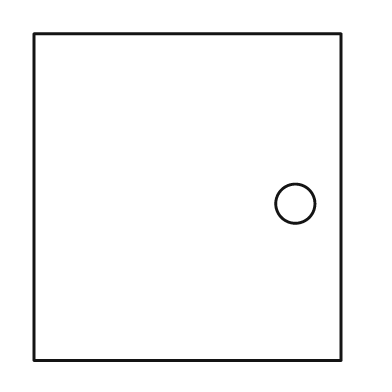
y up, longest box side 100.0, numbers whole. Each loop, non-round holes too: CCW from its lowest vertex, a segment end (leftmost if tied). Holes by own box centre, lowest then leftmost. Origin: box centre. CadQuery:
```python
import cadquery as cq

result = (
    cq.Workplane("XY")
    .moveTo(-47.0, -50.0)
    .lineTo(47.0, -50.0)
    .lineTo(47.0, 50.0)
    .lineTo(-47.0, 50.0)
    .close()
    .moveTo(33.0, -2.0)
    .circle(6.0)
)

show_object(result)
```